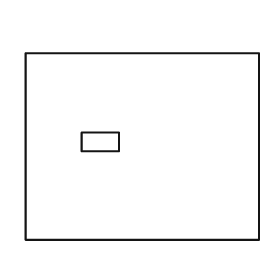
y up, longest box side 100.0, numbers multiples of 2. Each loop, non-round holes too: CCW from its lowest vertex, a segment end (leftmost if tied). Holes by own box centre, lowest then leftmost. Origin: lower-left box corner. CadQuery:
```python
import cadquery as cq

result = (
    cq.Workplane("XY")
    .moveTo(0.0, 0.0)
    .lineTo(100.0, 0.0)
    .lineTo(100.0, 80.0)
    .lineTo(0.0, 80.0)
    .close()
    .moveTo(24.0, 38.0)
    .lineTo(40.0, 38.0)
    .lineTo(40.0, 46.0)
    .lineTo(24.0, 46.0)
    .close()
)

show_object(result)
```